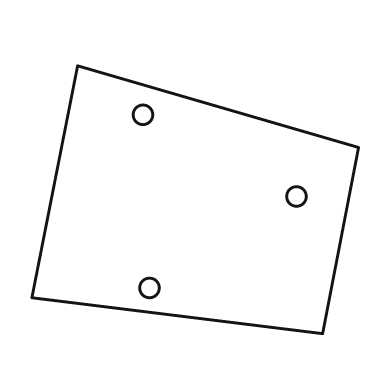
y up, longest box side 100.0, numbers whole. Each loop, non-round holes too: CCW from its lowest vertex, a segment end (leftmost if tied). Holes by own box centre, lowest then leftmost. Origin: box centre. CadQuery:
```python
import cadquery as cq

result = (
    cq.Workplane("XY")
    .moveTo(39.0, -41.0)
    .lineTo(50.0, 16.0)
    .lineTo(-36.0, 41.0)
    .lineTo(-50.0, -30.0)
    .close()
    .moveTo(-14.0, -27.0)
    .circle(3.0)
    .moveTo(31.0, 1.0)
    .circle(3.0)
    .moveTo(-16.0, 26.0)
    .circle(3.0)
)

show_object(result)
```